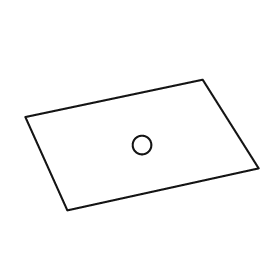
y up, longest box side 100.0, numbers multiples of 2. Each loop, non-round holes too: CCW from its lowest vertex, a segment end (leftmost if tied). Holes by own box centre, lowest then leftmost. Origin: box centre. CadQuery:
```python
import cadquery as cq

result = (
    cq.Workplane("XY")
    .moveTo(-32.0, -28.0)
    .lineTo(50.0, -10.0)
    .lineTo(26.0, 28.0)
    .lineTo(-50.0, 12.0)
    .close()
    .moveTo(0.0, 0.0)
    .circle(4.0)
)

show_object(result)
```